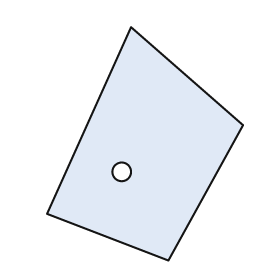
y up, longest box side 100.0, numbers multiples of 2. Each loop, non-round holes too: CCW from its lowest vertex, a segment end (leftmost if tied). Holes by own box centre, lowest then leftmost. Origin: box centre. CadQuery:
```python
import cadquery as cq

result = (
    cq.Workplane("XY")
    .moveTo(10.0, -50.0)
    .lineTo(42.0, 8.0)
    .lineTo(-6.0, 50.0)
    .lineTo(-42.0, -30.0)
    .close()
    .moveTo(-10.0, -12.0)
    .circle(4.0)
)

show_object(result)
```